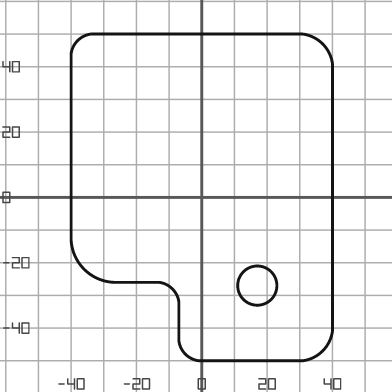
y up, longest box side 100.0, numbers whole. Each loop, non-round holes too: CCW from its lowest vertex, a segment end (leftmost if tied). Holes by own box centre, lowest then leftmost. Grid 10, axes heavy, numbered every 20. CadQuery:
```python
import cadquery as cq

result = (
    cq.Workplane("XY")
    .moveTo(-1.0, -50.0)
    .lineTo(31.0, -50.0)
    .threePointArc((37.0, -47.0), (40.0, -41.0))
    .lineTo(40.0, 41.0)
    .threePointArc((37.0, 47.0), (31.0, 50.0))
    .lineTo(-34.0, 50.0)
    .threePointArc((-38.0, 48.0), (-40.0, 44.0))
    .lineTo(-40.0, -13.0)
    .threePointArc((-36.0, -22.0), (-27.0, -26.0))
    .lineTo(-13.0, -26.0)
    .threePointArc((-9.0, -28.0), (-7.0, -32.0))
    .lineTo(-7.0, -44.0)
    .threePointArc((-5.0, -48.0), (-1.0, -50.0))
    .close()
    .moveTo(17.0, -27.0)
    .circle(6.0)
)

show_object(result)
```